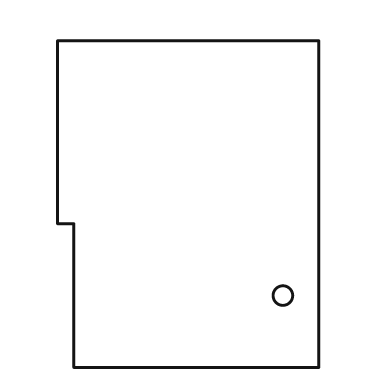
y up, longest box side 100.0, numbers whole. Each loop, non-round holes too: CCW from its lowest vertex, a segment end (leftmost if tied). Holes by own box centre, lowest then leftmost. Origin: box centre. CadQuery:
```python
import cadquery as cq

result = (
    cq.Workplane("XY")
    .moveTo(-35.0, -50.0)
    .lineTo(40.0, -50.0)
    .lineTo(40.0, 50.0)
    .lineTo(-40.0, 50.0)
    .lineTo(-40.0, -6.0)
    .lineTo(-35.0, -6.0)
    .close()
    .moveTo(29.0, -28.0)
    .circle(3.0)
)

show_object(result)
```